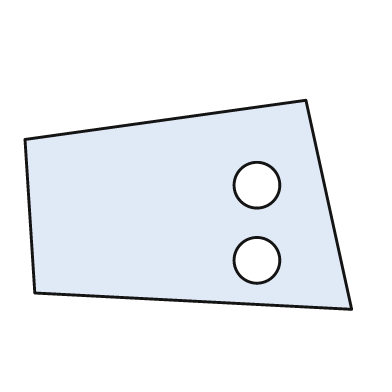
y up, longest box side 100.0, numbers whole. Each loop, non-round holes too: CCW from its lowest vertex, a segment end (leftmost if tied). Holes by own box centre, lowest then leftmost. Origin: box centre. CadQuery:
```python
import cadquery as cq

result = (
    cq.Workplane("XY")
    .moveTo(50.0, -32.0)
    .lineTo(36.0, 32.0)
    .lineTo(-50.0, 20.0)
    .lineTo(-47.0, -27.0)
    .close()
    .moveTo(21.0, -17.0)
    .circle(7.0)
    .moveTo(21.0, 6.0)
    .circle(7.0)
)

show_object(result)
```